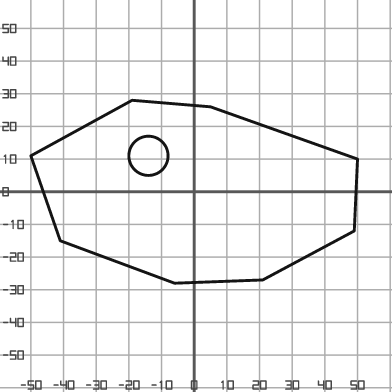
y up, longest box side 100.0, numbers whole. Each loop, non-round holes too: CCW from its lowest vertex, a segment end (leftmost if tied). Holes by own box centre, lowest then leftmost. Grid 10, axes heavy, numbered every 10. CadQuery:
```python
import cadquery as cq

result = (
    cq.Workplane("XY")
    .moveTo(-6.0, -28.0)
    .lineTo(21.0, -27.0)
    .lineTo(49.0, -12.0)
    .lineTo(50.0, 10.0)
    .lineTo(5.0, 26.0)
    .lineTo(-19.0, 28.0)
    .lineTo(-50.0, 11.0)
    .lineTo(-41.0, -15.0)
    .close()
    .moveTo(-14.0, 11.0)
    .circle(6.0)
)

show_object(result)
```